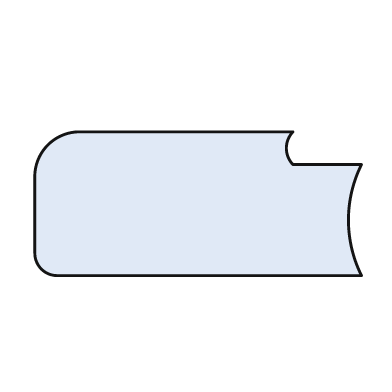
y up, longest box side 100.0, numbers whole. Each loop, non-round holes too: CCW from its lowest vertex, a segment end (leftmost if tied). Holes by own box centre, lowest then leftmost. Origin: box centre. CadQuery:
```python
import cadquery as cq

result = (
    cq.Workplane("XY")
    .moveTo(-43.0, -22.0)
    .lineTo(50.0, -22.0)
    .threePointArc((46.0, -5.0), (50.0, 12.0))
    .lineTo(29.0, 12.0)
    .threePointArc((27.0, 17.0), (29.0, 22.0))
    .lineTo(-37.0, 22.0)
    .threePointArc((-46.0, 18.0), (-50.0, 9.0))
    .lineTo(-50.0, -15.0)
    .threePointArc((-48.0, -20.0), (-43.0, -22.0))
    .close()
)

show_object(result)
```